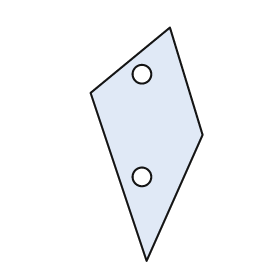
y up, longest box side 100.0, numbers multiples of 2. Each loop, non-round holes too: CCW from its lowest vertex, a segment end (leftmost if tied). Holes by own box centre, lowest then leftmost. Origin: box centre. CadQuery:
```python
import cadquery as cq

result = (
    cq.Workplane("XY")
    .moveTo(0.0, -50.0)
    .lineTo(24.0, 4.0)
    .lineTo(10.0, 50.0)
    .lineTo(-24.0, 22.0)
    .close()
    .moveTo(-2.0, -14.0)
    .circle(4.0)
    .moveTo(-2.0, 30.0)
    .circle(4.0)
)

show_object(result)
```